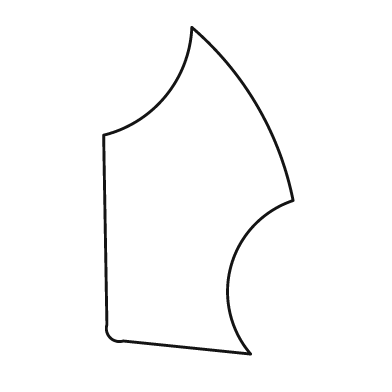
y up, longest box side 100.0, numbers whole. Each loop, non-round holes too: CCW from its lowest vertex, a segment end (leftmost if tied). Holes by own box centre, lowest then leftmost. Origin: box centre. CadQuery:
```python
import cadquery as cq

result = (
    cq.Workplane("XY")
    .moveTo(16.0, -50.0)
    .threePointArc((10.0, -23.0), (29.0, -3.0))
    .threePointArc((18.0, 26.0), (-2.0, 50.0))
    .threePointArc((-10.0, 29.0), (-29.0, 17.0))
    .lineTo(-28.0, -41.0)
    .threePointArc((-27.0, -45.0), (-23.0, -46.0))
    .close()
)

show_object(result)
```